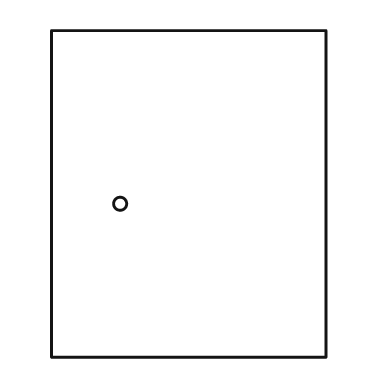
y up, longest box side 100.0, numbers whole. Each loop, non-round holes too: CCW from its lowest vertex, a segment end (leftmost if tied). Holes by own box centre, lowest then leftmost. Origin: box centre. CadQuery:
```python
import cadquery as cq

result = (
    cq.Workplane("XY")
    .moveTo(-42.0, -50.0)
    .lineTo(42.0, -50.0)
    .lineTo(42.0, 50.0)
    .lineTo(-42.0, 50.0)
    .close()
    .moveTo(-21.0, -3.0)
    .circle(2.0)
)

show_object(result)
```